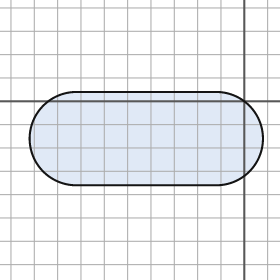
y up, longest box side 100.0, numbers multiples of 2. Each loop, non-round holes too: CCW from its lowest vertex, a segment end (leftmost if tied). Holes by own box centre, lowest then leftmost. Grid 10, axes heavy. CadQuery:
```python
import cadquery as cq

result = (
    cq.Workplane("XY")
    .moveTo(-72.0, -36.0)
    .lineTo(-12.0, -36.0)
    .threePointArc((8.0, -16.0), (-12.0, 4.0))
    .lineTo(-72.0, 4.0)
    .threePointArc((-92.0, -16.0), (-72.0, -36.0))
    .close()
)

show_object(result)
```